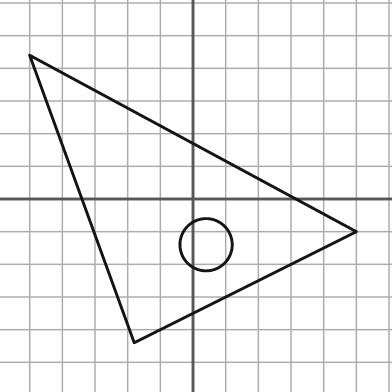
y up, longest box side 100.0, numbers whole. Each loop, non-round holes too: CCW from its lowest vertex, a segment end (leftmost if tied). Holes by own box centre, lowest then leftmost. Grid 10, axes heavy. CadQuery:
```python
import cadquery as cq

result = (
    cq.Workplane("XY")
    .moveTo(-18.0, -44.0)
    .lineTo(50.0, -10.0)
    .lineTo(-50.0, 44.0)
    .close()
    .moveTo(4.0, -14.0)
    .circle(8.0)
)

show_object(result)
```